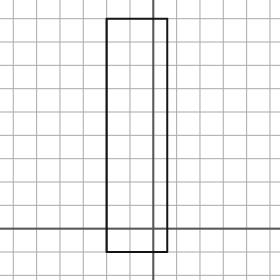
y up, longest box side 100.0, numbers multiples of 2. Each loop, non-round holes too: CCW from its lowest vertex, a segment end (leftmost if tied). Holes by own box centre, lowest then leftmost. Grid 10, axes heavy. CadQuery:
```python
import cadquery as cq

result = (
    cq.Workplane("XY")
    .moveTo(-20.0, -10.0)
    .lineTo(6.0, -10.0)
    .lineTo(6.0, 90.0)
    .lineTo(-20.0, 90.0)
    .close()
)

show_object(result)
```